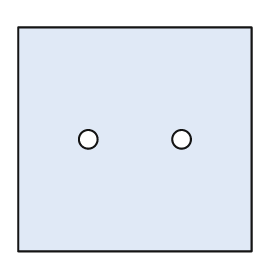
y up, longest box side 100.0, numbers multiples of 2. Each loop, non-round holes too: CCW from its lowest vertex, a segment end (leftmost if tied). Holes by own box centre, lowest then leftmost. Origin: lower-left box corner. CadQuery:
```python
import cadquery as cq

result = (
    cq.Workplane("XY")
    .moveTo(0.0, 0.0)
    .lineTo(100.0, 0.0)
    .lineTo(100.0, 96.0)
    .lineTo(0.0, 96.0)
    .close()
    .moveTo(30.0, 48.0)
    .circle(4.0)
    .moveTo(70.0, 48.0)
    .circle(4.0)
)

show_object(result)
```